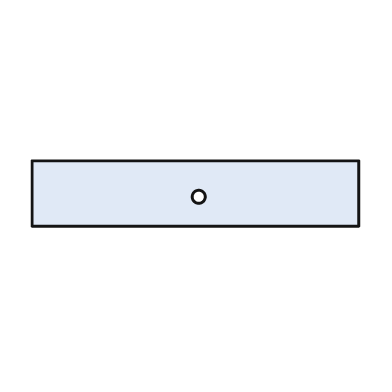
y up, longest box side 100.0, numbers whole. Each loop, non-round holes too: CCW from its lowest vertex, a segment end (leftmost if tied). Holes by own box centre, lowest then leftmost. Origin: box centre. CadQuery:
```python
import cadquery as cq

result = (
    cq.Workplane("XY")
    .moveTo(-50.0, -10.0)
    .lineTo(50.0, -10.0)
    .lineTo(50.0, 10.0)
    .lineTo(-50.0, 10.0)
    .close()
    .moveTo(1.0, -1.0)
    .circle(2.0)
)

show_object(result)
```